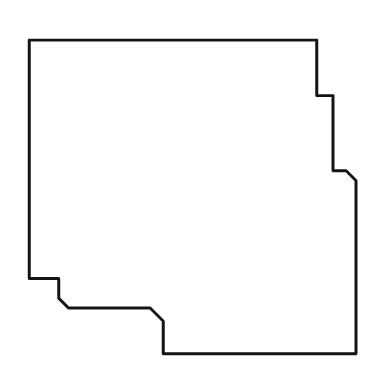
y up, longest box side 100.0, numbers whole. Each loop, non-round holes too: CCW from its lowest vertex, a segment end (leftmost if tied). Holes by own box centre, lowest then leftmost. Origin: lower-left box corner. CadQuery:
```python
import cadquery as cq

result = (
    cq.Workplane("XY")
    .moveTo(41.0, 0.0)
    .lineTo(100.0, 0.0)
    .lineTo(100.0, 53.0)
    .lineTo(97.0, 56.0)
    .lineTo(93.0, 56.0)
    .lineTo(93.0, 79.0)
    .lineTo(88.0, 79.0)
    .lineTo(88.0, 96.0)
    .lineTo(0.0, 96.0)
    .lineTo(0.0, 23.0)
    .lineTo(9.0, 23.0)
    .lineTo(9.0, 17.0)
    .lineTo(12.0, 14.0)
    .lineTo(37.0, 14.0)
    .lineTo(41.0, 10.0)
    .close()
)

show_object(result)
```